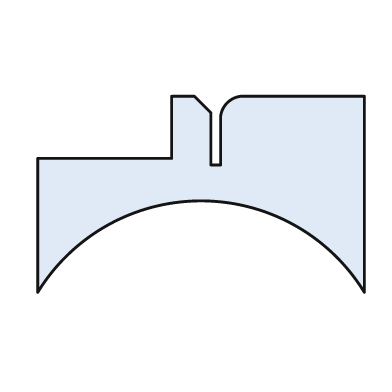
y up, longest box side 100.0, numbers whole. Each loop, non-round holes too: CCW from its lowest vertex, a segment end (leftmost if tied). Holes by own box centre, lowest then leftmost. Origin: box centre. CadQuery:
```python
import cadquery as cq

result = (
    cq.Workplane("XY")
    .moveTo(-50.0, -30.0)
    .threePointArc((0.0, -2.0), (50.0, -30.0))
    .lineTo(50.0, 30.0)
    .lineTo(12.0, 30.0)
    .threePointArc((8.0, 28.0), (6.0, 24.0))
    .lineTo(6.0, 9.0)
    .lineTo(3.0, 9.0)
    .lineTo(3.0, 25.0)
    .lineTo(-2.0, 30.0)
    .lineTo(-9.0, 30.0)
    .lineTo(-9.0, 11.0)
    .lineTo(-50.0, 11.0)
    .close()
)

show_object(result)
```